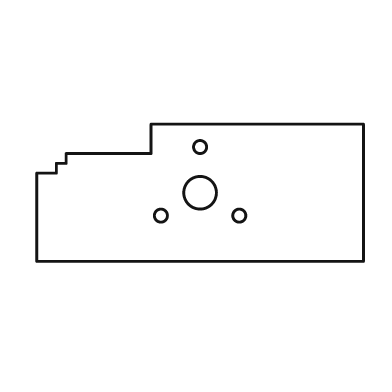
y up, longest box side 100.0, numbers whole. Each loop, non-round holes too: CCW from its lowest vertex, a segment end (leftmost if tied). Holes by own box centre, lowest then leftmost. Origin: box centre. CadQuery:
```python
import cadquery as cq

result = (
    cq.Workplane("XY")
    .moveTo(-50.0, -21.0)
    .lineTo(50.0, -21.0)
    .lineTo(50.0, 21.0)
    .lineTo(-15.0, 21.0)
    .lineTo(-15.0, 12.0)
    .lineTo(-41.0, 12.0)
    .lineTo(-41.0, 9.0)
    .lineTo(-44.0, 9.0)
    .lineTo(-44.0, 6.0)
    .lineTo(-50.0, 6.0)
    .close()
    .moveTo(-12.0, -7.0)
    .circle(2.0)
    .moveTo(12.0, -7.0)
    .circle(2.0)
    .moveTo(0.0, 0.0)
    .circle(5.0)
    .moveTo(0.0, 14.0)
    .circle(2.0)
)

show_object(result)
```